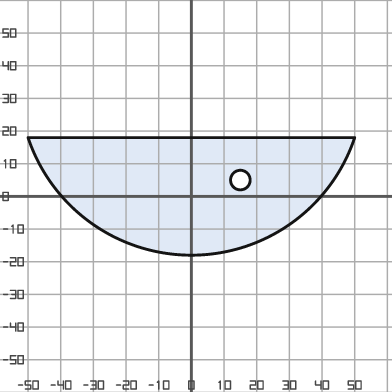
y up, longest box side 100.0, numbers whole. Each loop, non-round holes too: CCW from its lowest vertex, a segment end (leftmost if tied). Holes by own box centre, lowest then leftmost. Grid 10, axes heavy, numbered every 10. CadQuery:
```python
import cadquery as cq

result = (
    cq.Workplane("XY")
    .moveTo(-50.0, 18.0)
    .threePointArc((0.0, -18.0), (50.0, 18.0))
    .close()
    .moveTo(15.0, 5.0)
    .circle(3.0)
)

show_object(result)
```